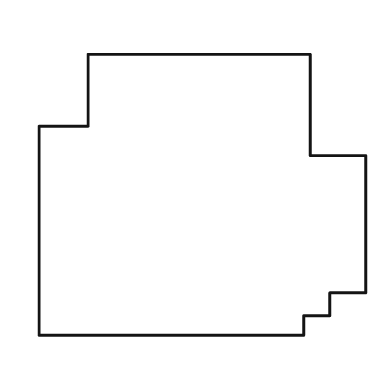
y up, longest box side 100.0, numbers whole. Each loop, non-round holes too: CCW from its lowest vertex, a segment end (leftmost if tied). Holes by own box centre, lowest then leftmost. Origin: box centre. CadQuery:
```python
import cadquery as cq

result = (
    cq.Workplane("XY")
    .moveTo(-50.0, -43.0)
    .lineTo(31.0, -43.0)
    .lineTo(31.0, -37.0)
    .lineTo(39.0, -37.0)
    .lineTo(39.0, -30.0)
    .lineTo(50.0, -30.0)
    .lineTo(50.0, 12.0)
    .lineTo(33.0, 12.0)
    .lineTo(33.0, 43.0)
    .lineTo(-35.0, 43.0)
    .lineTo(-35.0, 21.0)
    .lineTo(-50.0, 21.0)
    .close()
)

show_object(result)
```